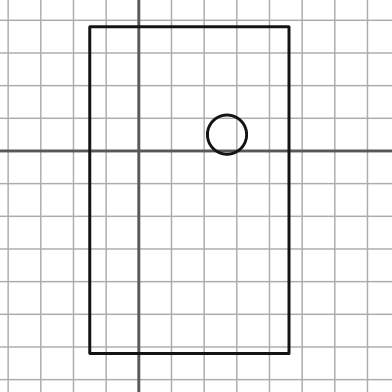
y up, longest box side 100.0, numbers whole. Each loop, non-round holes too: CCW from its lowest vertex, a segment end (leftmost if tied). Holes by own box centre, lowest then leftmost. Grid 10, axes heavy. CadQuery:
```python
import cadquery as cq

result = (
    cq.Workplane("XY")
    .moveTo(-15.0, -62.0)
    .lineTo(46.0, -62.0)
    .lineTo(46.0, 38.0)
    .lineTo(-15.0, 38.0)
    .close()
    .moveTo(27.0, 5.0)
    .circle(6.0)
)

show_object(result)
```